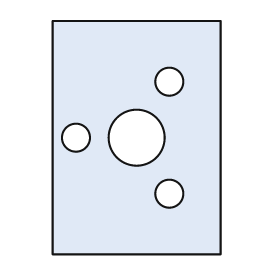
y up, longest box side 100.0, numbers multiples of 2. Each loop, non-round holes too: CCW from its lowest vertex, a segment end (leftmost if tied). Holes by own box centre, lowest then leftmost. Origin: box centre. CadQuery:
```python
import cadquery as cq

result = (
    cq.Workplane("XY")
    .moveTo(-36.0, -50.0)
    .lineTo(36.0, -50.0)
    .lineTo(36.0, 50.0)
    .lineTo(-36.0, 50.0)
    .close()
    .moveTo(14.0, -24.0)
    .circle(6.0)
    .moveTo(-26.0, 0.0)
    .circle(6.0)
    .moveTo(0.0, 0.0)
    .circle(12.0)
    .moveTo(14.0, 24.0)
    .circle(6.0)
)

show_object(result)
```